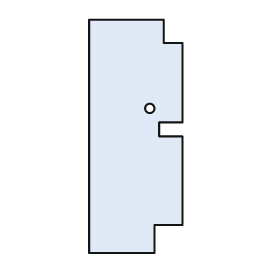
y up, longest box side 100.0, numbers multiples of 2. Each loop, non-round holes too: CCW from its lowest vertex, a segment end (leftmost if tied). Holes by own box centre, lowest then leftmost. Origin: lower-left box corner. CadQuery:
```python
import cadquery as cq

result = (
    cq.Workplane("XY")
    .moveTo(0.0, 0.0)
    .lineTo(28.0, 0.0)
    .lineTo(28.0, 12.0)
    .lineTo(40.0, 12.0)
    .lineTo(40.0, 50.0)
    .lineTo(30.0, 50.0)
    .lineTo(30.0, 56.0)
    .lineTo(40.0, 56.0)
    .lineTo(40.0, 90.0)
    .lineTo(32.0, 90.0)
    .lineTo(32.0, 100.0)
    .lineTo(0.0, 100.0)
    .close()
    .moveTo(26.0, 62.0)
    .circle(2.0)
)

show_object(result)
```